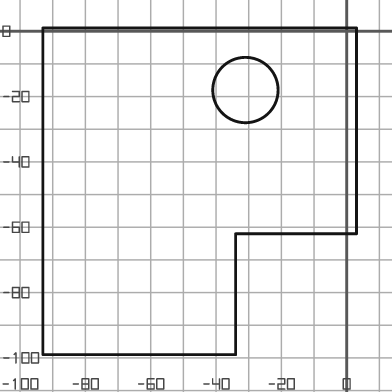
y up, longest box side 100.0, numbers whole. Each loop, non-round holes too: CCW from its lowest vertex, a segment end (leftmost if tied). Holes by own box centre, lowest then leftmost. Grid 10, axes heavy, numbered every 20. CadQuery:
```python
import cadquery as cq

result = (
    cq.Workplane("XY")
    .moveTo(-93.0, -99.0)
    .lineTo(-34.0, -99.0)
    .lineTo(-34.0, -62.0)
    .lineTo(3.0, -62.0)
    .lineTo(3.0, 1.0)
    .lineTo(-93.0, 1.0)
    .close()
    .moveTo(-31.0, -18.0)
    .circle(10.0)
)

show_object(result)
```